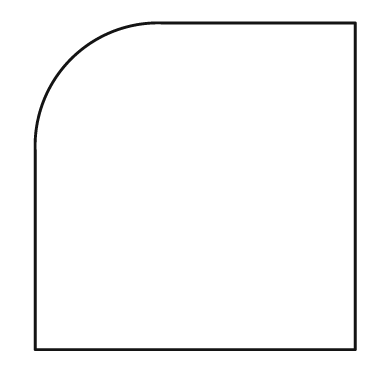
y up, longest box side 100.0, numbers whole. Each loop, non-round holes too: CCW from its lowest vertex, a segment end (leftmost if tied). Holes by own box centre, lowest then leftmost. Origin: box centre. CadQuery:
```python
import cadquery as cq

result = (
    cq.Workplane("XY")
    .moveTo(-49.0, -50.0)
    .lineTo(49.0, -50.0)
    .lineTo(49.0, 50.0)
    .lineTo(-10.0, 50.0)
    .threePointArc((-38.0, 39.0), (-49.0, 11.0))
    .close()
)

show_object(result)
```